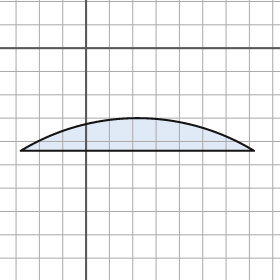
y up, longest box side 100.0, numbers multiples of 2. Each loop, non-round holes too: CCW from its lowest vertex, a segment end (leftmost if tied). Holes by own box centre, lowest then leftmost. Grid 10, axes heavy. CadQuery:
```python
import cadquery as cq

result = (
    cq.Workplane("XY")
    .moveTo(-28.0, -44.0)
    .lineTo(72.0, -44.0)
    .threePointArc((22.0, -30.0), (-28.0, -44.0))
    .close()
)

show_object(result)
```